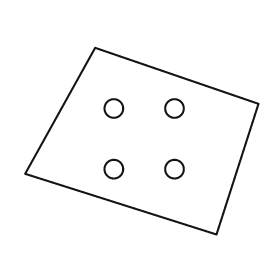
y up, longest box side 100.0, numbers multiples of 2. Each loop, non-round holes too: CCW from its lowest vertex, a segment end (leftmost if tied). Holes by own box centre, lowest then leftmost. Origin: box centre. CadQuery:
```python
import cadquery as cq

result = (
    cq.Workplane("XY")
    .moveTo(32.0, -40.0)
    .lineTo(50.0, 16.0)
    .lineTo(-20.0, 40.0)
    .lineTo(-50.0, -14.0)
    .close()
    .moveTo(-12.0, -12.0)
    .circle(4.0)
    .moveTo(14.0, -12.0)
    .circle(4.0)
    .moveTo(-12.0, 14.0)
    .circle(4.0)
    .moveTo(14.0, 14.0)
    .circle(4.0)
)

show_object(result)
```